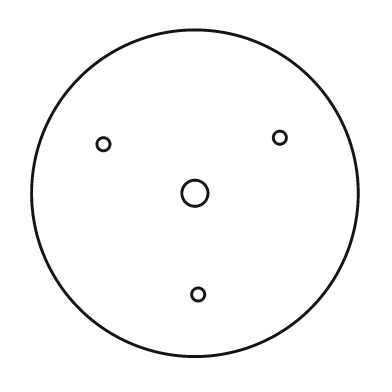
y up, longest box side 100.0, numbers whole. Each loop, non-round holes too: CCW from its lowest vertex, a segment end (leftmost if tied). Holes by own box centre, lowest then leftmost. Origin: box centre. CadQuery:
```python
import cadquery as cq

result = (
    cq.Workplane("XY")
    .moveTo(0.0, 0.0)
    .circle(50.0)
    .moveTo(1.0, -31.0)
    .circle(2.0)
    .moveTo(0.0, 0.0)
    .circle(4.0)
    .moveTo(-28.0, 15.0)
    .circle(2.0)
    .moveTo(26.0, 17.0)
    .circle(2.0)
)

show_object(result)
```